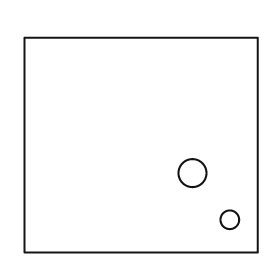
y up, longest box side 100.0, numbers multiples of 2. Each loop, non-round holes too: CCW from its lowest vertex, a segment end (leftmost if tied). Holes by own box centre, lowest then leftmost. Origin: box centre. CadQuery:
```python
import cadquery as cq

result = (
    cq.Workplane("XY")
    .moveTo(-50.0, -46.0)
    .lineTo(50.0, -46.0)
    .lineTo(50.0, 46.0)
    .lineTo(-50.0, 46.0)
    .close()
    .moveTo(38.0, -32.0)
    .circle(4.0)
    .moveTo(22.0, -12.0)
    .circle(6.0)
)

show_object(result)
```